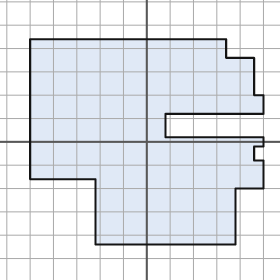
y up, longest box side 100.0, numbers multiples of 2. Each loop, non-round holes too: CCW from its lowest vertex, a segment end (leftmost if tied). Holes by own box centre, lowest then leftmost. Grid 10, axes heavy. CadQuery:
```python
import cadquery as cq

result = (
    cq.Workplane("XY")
    .moveTo(-22.0, -44.0)
    .lineTo(38.0, -44.0)
    .lineTo(38.0, -20.0)
    .lineTo(50.0, -20.0)
    .lineTo(50.0, -8.0)
    .lineTo(46.0, -8.0)
    .lineTo(46.0, -2.0)
    .lineTo(50.0, -2.0)
    .lineTo(50.0, 2.0)
    .lineTo(8.0, 2.0)
    .lineTo(8.0, 12.0)
    .lineTo(50.0, 12.0)
    .lineTo(50.0, 20.0)
    .lineTo(46.0, 20.0)
    .lineTo(46.0, 36.0)
    .lineTo(34.0, 36.0)
    .lineTo(34.0, 44.0)
    .lineTo(-50.0, 44.0)
    .lineTo(-50.0, -16.0)
    .lineTo(-22.0, -16.0)
    .close()
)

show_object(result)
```